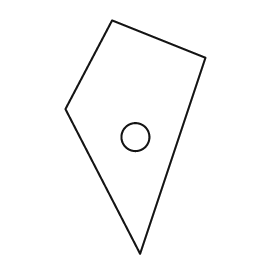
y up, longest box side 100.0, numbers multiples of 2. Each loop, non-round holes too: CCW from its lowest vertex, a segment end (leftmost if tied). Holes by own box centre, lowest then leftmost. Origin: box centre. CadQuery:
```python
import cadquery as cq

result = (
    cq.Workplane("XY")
    .moveTo(2.0, -50.0)
    .lineTo(30.0, 34.0)
    .lineTo(-10.0, 50.0)
    .lineTo(-30.0, 12.0)
    .close()
    .moveTo(0.0, 0.0)
    .circle(6.0)
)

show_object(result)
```